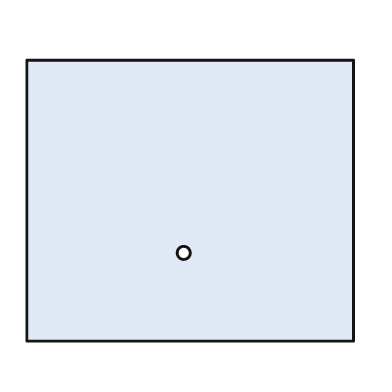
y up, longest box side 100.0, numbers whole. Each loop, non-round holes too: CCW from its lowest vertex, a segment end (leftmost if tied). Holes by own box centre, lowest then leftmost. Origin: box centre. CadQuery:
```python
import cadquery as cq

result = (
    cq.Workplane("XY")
    .moveTo(-50.0, -43.0)
    .lineTo(50.0, -43.0)
    .lineTo(50.0, 43.0)
    .lineTo(-50.0, 43.0)
    .close()
    .moveTo(-2.0, -16.0)
    .circle(2.0)
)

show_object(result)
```